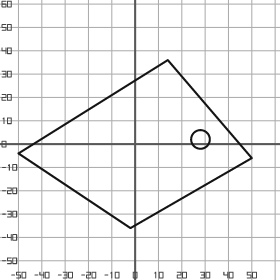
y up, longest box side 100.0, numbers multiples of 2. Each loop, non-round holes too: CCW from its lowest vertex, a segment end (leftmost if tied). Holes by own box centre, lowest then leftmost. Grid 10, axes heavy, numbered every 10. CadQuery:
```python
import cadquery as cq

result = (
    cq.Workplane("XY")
    .moveTo(-2.0, -36.0)
    .lineTo(50.0, -6.0)
    .lineTo(14.0, 36.0)
    .lineTo(-50.0, -4.0)
    .close()
    .moveTo(28.0, 2.0)
    .circle(4.0)
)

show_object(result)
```